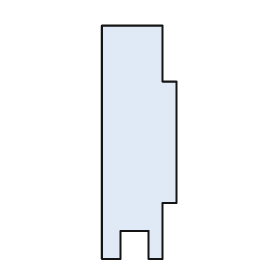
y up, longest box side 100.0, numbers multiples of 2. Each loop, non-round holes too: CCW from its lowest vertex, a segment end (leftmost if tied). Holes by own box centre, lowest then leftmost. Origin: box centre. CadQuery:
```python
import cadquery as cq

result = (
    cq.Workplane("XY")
    .moveTo(-16.0, -50.0)
    .lineTo(-8.0, -50.0)
    .lineTo(-8.0, -38.0)
    .lineTo(4.0, -38.0)
    .lineTo(4.0, -50.0)
    .lineTo(10.0, -50.0)
    .lineTo(10.0, -26.0)
    .lineTo(16.0, -26.0)
    .lineTo(16.0, 26.0)
    .lineTo(10.0, 26.0)
    .lineTo(10.0, 50.0)
    .lineTo(-16.0, 50.0)
    .close()
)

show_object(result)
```